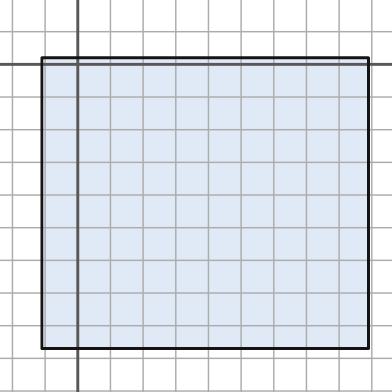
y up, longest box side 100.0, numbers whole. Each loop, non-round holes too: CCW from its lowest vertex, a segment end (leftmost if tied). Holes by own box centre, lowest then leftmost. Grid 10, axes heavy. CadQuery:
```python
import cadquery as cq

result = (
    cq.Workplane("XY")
    .moveTo(-11.0, -87.0)
    .lineTo(89.0, -87.0)
    .lineTo(89.0, 2.0)
    .lineTo(-11.0, 2.0)
    .close()
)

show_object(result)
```